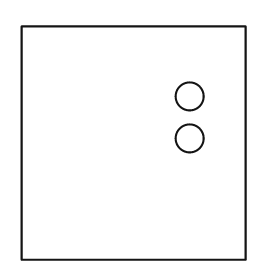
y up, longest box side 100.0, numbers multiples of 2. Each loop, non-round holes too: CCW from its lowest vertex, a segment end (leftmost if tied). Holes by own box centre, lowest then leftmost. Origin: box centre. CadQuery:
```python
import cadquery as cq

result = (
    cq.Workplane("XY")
    .moveTo(-48.0, -50.0)
    .lineTo(48.0, -50.0)
    .lineTo(48.0, 50.0)
    .lineTo(-48.0, 50.0)
    .close()
    .moveTo(24.0, 2.0)
    .circle(6.0)
    .moveTo(24.0, 20.0)
    .circle(6.0)
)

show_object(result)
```